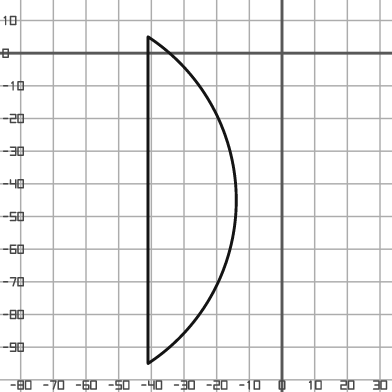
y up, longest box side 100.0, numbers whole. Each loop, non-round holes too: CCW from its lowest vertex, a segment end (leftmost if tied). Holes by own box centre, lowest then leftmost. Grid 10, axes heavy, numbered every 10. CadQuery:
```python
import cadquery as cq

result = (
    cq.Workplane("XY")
    .moveTo(-41.0, -95.0)
    .threePointArc((-14.0, -45.0), (-41.0, 5.0))
    .close()
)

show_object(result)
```